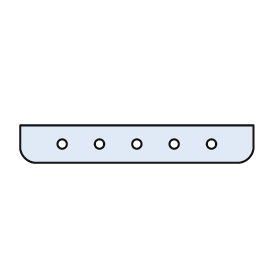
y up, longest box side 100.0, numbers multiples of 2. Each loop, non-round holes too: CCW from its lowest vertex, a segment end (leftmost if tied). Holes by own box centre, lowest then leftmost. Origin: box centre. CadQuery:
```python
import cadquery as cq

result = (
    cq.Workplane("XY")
    .moveTo(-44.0, -8.0)
    .lineTo(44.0, -8.0)
    .threePointArc((48.0, -6.0), (50.0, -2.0))
    .lineTo(50.0, 8.0)
    .lineTo(-50.0, 8.0)
    .lineTo(-50.0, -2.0)
    .threePointArc((-48.0, -6.0), (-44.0, -8.0))
    .close()
    .moveTo(-32.0, 0.0)
    .circle(2.0)
    .moveTo(-16.0, 0.0)
    .circle(2.0)
    .moveTo(0.0, 0.0)
    .circle(2.0)
    .moveTo(16.0, 0.0)
    .circle(2.0)
    .moveTo(32.0, 0.0)
    .circle(2.0)
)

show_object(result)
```